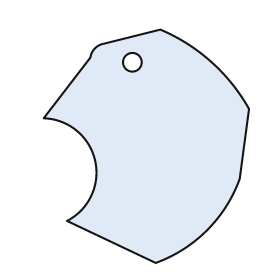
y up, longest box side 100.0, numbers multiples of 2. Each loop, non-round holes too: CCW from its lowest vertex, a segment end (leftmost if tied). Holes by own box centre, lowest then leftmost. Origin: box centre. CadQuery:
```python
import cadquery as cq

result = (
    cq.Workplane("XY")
    .moveTo(4.0, -50.0)
    .threePointArc((26.0, -36.0), (40.0, -14.0))
    .lineTo(44.0, 16.0)
    .threePointArc((28.0, 36.0), (6.0, 50.0))
    .lineTo(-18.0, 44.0)
    .threePointArc((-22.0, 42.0), (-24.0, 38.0))
    .lineTo(-44.0, 12.0)
    .threePointArc((-22.0, -6.0), (-34.0, -32.0))
    .close()
    .moveTo(-6.0, 36.0)
    .circle(4.0)
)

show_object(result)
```